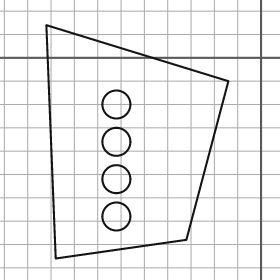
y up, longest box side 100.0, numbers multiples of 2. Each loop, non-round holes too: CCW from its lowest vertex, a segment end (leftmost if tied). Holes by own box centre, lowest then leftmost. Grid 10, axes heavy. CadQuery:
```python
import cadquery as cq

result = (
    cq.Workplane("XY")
    .moveTo(-88.0, -86.0)
    .lineTo(-32.0, -78.0)
    .lineTo(-14.0, -10.0)
    .lineTo(-92.0, 14.0)
    .close()
    .moveTo(-62.0, -68.0)
    .circle(6.0)
    .moveTo(-62.0, -52.0)
    .circle(6.0)
    .moveTo(-62.0, -36.0)
    .circle(6.0)
    .moveTo(-62.0, -20.0)
    .circle(6.0)
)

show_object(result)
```